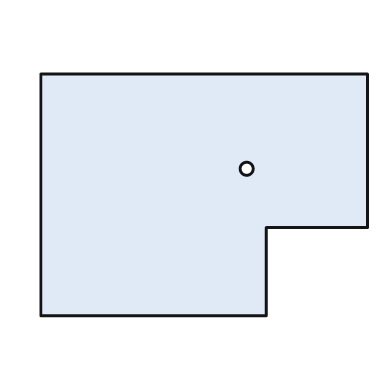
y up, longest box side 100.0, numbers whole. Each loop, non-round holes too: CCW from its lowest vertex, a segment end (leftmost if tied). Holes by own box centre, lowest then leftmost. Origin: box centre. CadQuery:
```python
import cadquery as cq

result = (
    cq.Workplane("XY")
    .moveTo(-50.0, -37.0)
    .lineTo(19.0, -37.0)
    .lineTo(19.0, -10.0)
    .lineTo(50.0, -10.0)
    .lineTo(50.0, 37.0)
    .lineTo(-50.0, 37.0)
    .close()
    .moveTo(13.0, 8.0)
    .circle(2.0)
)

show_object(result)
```